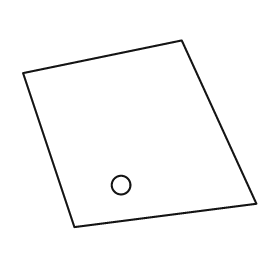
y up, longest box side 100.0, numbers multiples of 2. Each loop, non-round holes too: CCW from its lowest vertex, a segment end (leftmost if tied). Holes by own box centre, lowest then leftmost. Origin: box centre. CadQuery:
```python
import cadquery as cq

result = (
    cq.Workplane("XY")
    .moveTo(-28.0, -40.0)
    .lineTo(50.0, -30.0)
    .lineTo(18.0, 40.0)
    .lineTo(-50.0, 26.0)
    .close()
    .moveTo(-8.0, -22.0)
    .circle(4.0)
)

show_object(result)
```